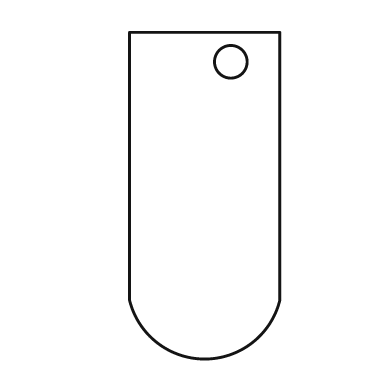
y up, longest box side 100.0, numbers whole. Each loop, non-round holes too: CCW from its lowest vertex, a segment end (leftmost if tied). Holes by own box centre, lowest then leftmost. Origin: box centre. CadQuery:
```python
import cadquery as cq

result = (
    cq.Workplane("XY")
    .moveTo(-23.0, -32.0)
    .threePointArc((0.0, -50.0), (23.0, -32.0))
    .lineTo(23.0, 50.0)
    .lineTo(-23.0, 50.0)
    .close()
    .moveTo(8.0, 41.0)
    .circle(5.0)
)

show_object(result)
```